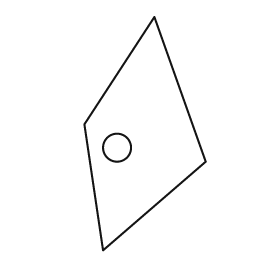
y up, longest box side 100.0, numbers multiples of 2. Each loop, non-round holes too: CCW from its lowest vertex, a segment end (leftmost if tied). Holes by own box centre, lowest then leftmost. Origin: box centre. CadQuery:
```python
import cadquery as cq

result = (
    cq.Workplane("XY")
    .moveTo(-18.0, -50.0)
    .lineTo(26.0, -12.0)
    .lineTo(4.0, 50.0)
    .lineTo(-26.0, 4.0)
    .close()
    .moveTo(-12.0, -6.0)
    .circle(6.0)
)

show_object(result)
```